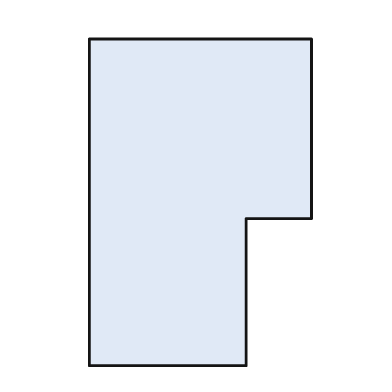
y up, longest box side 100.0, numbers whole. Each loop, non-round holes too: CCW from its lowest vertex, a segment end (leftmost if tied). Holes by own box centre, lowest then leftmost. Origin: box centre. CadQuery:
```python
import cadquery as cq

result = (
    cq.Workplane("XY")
    .moveTo(-34.0, -50.0)
    .lineTo(14.0, -50.0)
    .lineTo(14.0, -5.0)
    .lineTo(34.0, -5.0)
    .lineTo(34.0, 50.0)
    .lineTo(-34.0, 50.0)
    .close()
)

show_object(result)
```